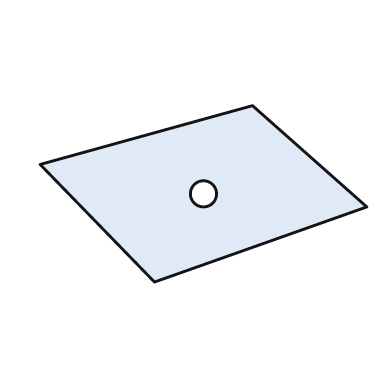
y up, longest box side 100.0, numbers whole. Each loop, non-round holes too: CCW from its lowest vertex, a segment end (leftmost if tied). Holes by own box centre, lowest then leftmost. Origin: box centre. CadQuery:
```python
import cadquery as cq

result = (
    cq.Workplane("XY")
    .moveTo(-15.0, -27.0)
    .lineTo(50.0, -4.0)
    .lineTo(15.0, 27.0)
    .lineTo(-50.0, 9.0)
    .close()
    .moveTo(0.0, 0.0)
    .circle(4.0)
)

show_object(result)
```